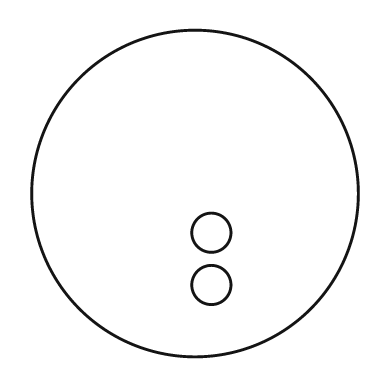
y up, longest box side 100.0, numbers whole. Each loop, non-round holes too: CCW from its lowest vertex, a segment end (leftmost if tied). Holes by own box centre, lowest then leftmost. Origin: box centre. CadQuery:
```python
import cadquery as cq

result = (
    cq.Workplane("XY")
    .moveTo(0.0, 0.0)
    .circle(50.0)
    .moveTo(5.0, -28.0)
    .circle(6.0)
    .moveTo(5.0, -12.0)
    .circle(6.0)
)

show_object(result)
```